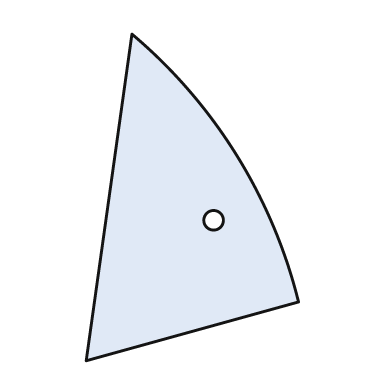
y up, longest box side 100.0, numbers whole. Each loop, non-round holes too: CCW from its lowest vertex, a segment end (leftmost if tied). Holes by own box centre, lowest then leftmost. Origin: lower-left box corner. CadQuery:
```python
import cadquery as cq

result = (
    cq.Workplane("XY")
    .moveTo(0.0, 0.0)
    .lineTo(65.0, 18.0)
    .threePointArc((46.0, 63.0), (14.0, 100.0))
    .close()
    .moveTo(39.0, 43.0)
    .circle(3.0)
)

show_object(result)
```